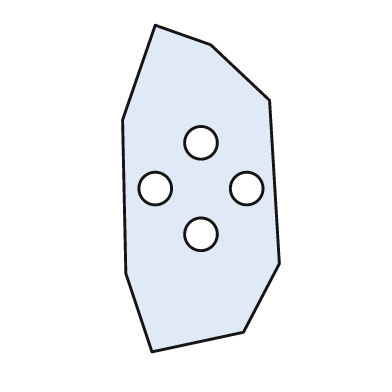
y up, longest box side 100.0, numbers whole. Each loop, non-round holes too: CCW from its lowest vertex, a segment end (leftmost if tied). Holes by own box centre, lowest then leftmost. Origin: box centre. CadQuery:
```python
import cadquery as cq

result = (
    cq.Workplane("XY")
    .moveTo(-15.0, -50.0)
    .lineTo(13.0, -44.0)
    .lineTo(24.0, -23.0)
    .lineTo(21.0, 27.0)
    .lineTo(3.0, 44.0)
    .lineTo(-14.0, 50.0)
    .lineTo(-24.0, 21.0)
    .lineTo(-23.0, -26.0)
    .close()
    .moveTo(0.0, -14.0)
    .circle(5.0)
    .moveTo(-14.0, 0.0)
    .circle(5.0)
    .moveTo(14.0, 0.0)
    .circle(5.0)
    .moveTo(0.0, 14.0)
    .circle(5.0)
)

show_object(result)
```